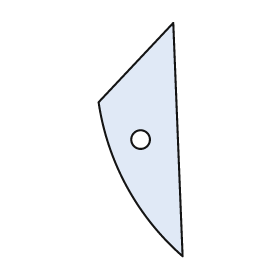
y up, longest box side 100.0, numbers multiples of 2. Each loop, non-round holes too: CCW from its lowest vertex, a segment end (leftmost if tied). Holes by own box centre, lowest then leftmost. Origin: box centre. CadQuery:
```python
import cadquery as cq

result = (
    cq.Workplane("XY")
    .moveTo(18.0, -50.0)
    .lineTo(14.0, 50.0)
    .lineTo(-18.0, 16.0)
    .threePointArc((-6.0, -20.0), (18.0, -50.0))
    .close()
    .moveTo(0.0, 0.0)
    .circle(4.0)
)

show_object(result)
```